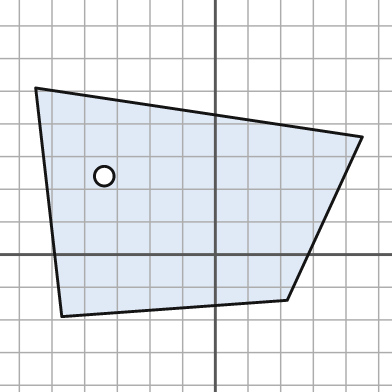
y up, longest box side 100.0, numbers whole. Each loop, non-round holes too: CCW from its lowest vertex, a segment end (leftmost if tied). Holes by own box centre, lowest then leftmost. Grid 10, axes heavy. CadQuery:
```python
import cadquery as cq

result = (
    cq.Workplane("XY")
    .moveTo(-47.0, -19.0)
    .lineTo(22.0, -14.0)
    .lineTo(45.0, 36.0)
    .lineTo(-55.0, 51.0)
    .close()
    .moveTo(-34.0, 24.0)
    .circle(3.0)
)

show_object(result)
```